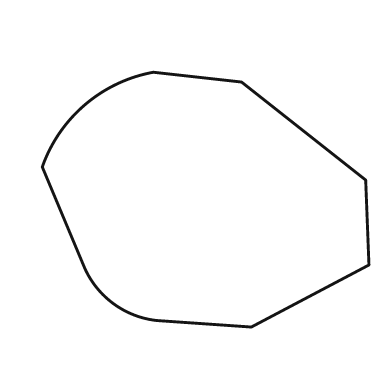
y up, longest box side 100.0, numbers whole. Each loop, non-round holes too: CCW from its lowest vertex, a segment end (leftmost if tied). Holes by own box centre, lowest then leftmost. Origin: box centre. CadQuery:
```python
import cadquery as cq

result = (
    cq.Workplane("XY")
    .moveTo(14.0, -39.0)
    .lineTo(50.0, -20.0)
    .lineTo(49.0, 6.0)
    .lineTo(11.0, 36.0)
    .lineTo(-16.0, 39.0)
    .threePointArc((-37.0, 29.0), (-50.0, 10.0))
    .lineTo(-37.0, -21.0)
    .threePointArc((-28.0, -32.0), (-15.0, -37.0))
    .close()
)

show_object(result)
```